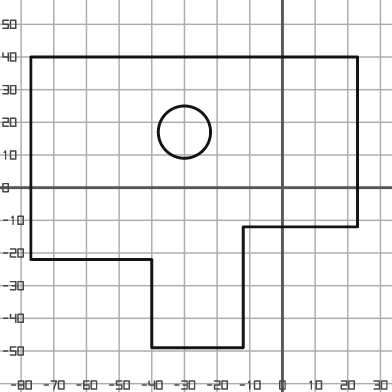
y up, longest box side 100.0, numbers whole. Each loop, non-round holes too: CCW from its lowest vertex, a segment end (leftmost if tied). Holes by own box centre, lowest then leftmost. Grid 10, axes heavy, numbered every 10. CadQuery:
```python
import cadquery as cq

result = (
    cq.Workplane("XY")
    .moveTo(-40.0, -49.0)
    .lineTo(-12.0, -49.0)
    .lineTo(-12.0, -12.0)
    .lineTo(23.0, -12.0)
    .lineTo(23.0, 40.0)
    .lineTo(-77.0, 40.0)
    .lineTo(-77.0, -22.0)
    .lineTo(-40.0, -22.0)
    .close()
    .moveTo(-30.0, 17.0)
    .circle(8.0)
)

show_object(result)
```